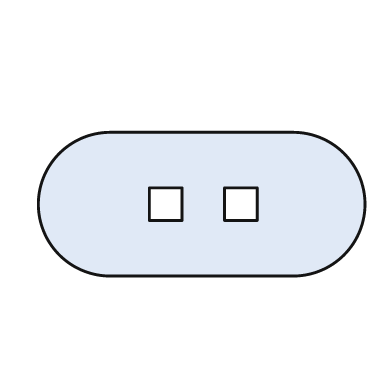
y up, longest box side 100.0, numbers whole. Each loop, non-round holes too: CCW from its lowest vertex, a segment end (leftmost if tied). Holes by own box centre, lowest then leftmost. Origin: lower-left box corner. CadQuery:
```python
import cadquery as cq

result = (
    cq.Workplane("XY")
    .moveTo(22.0, 0.0)
    .lineTo(78.0, 0.0)
    .threePointArc((100.0, 22.0), (78.0, 44.0))
    .lineTo(22.0, 44.0)
    .threePointArc((0.0, 22.0), (22.0, 0.0))
    .close()
    .moveTo(34.0, 17.0)
    .lineTo(44.0, 17.0)
    .lineTo(44.0, 27.0)
    .lineTo(34.0, 27.0)
    .close()
    .moveTo(57.0, 17.0)
    .lineTo(67.0, 17.0)
    .lineTo(67.0, 27.0)
    .lineTo(57.0, 27.0)
    .close()
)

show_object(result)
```